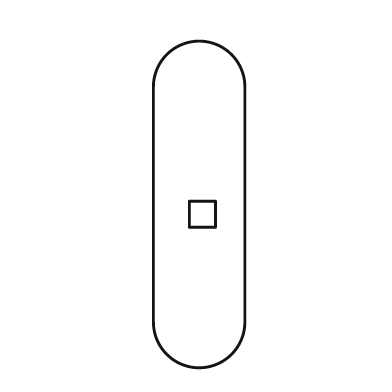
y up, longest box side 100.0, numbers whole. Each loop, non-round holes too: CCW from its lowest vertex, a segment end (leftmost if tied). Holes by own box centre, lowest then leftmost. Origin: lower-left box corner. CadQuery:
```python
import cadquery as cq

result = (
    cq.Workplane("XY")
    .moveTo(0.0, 14.0)
    .threePointArc((14.0, 0.0), (28.0, 14.0))
    .lineTo(28.0, 86.0)
    .threePointArc((14.0, 100.0), (0.0, 86.0))
    .close()
    .moveTo(11.0, 43.0)
    .lineTo(19.0, 43.0)
    .lineTo(19.0, 51.0)
    .lineTo(11.0, 51.0)
    .close()
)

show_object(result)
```